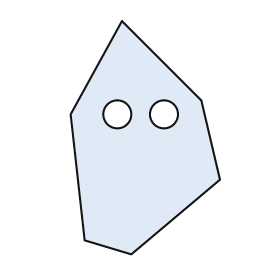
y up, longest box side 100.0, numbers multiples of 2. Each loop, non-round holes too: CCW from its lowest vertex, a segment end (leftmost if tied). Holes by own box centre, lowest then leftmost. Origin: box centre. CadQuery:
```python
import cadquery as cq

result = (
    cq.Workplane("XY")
    .moveTo(-6.0, -50.0)
    .lineTo(32.0, -18.0)
    .lineTo(24.0, 16.0)
    .lineTo(-10.0, 50.0)
    .lineTo(-32.0, 10.0)
    .lineTo(-26.0, -44.0)
    .close()
    .moveTo(-12.0, 10.0)
    .circle(6.0)
    .moveTo(8.0, 10.0)
    .circle(6.0)
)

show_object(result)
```